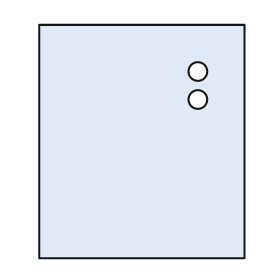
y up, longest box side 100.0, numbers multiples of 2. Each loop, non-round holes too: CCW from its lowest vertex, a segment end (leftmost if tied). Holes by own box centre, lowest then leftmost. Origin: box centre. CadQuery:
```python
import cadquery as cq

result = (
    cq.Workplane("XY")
    .moveTo(-44.0, -50.0)
    .lineTo(44.0, -50.0)
    .lineTo(44.0, 50.0)
    .lineTo(-44.0, 50.0)
    .close()
    .moveTo(24.0, 18.0)
    .circle(4.0)
    .moveTo(24.0, 30.0)
    .circle(4.0)
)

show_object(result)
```